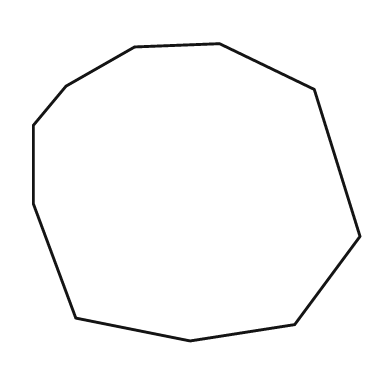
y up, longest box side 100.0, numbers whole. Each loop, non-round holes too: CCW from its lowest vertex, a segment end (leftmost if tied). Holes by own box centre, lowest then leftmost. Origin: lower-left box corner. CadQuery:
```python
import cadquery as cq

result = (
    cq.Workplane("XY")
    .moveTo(48.0, 0.0)
    .lineTo(80.0, 5.0)
    .lineTo(100.0, 32.0)
    .lineTo(86.0, 77.0)
    .lineTo(57.0, 91.0)
    .lineTo(31.0, 90.0)
    .lineTo(10.0, 78.0)
    .lineTo(0.0, 66.0)
    .lineTo(0.0, 42.0)
    .lineTo(13.0, 7.0)
    .close()
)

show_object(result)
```